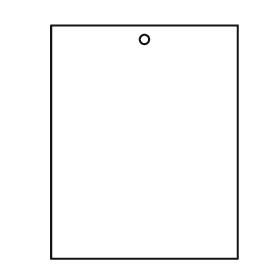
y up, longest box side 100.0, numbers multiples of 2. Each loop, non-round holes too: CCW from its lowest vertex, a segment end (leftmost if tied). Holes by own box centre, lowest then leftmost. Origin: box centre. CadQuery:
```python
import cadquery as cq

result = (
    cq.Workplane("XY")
    .moveTo(-40.0, -50.0)
    .lineTo(40.0, -50.0)
    .lineTo(40.0, 50.0)
    .lineTo(-40.0, 50.0)
    .close()
    .moveTo(0.0, 44.0)
    .circle(2.0)
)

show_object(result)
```